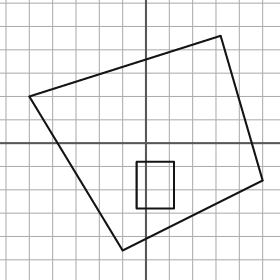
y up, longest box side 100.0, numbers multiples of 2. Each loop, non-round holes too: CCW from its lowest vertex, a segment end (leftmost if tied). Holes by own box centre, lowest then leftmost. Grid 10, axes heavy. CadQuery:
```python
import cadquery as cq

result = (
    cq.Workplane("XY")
    .moveTo(-10.0, -46.0)
    .lineTo(50.0, -16.0)
    .lineTo(32.0, 46.0)
    .lineTo(-50.0, 20.0)
    .close()
    .moveTo(-4.0, -28.0)
    .lineTo(12.0, -28.0)
    .lineTo(12.0, -8.0)
    .lineTo(-4.0, -8.0)
    .close()
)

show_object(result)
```